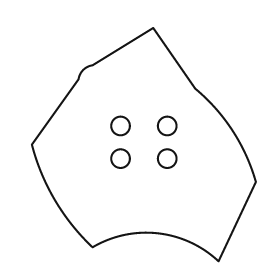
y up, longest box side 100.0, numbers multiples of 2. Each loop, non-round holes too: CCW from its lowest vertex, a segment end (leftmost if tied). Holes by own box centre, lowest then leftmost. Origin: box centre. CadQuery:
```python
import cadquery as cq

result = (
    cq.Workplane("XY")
    .moveTo(32.0, -50.0)
    .lineTo(48.0, -16.0)
    .threePointArc((38.0, 6.0), (22.0, 24.0))
    .lineTo(4.0, 50.0)
    .lineTo(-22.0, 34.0)
    .threePointArc((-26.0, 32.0), (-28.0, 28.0))
    .lineTo(-48.0, 0.0)
    .threePointArc((-38.0, -24.0), (-22.0, -44.0))
    .threePointArc((6.0, -38.0), (32.0, -50.0))
    .close()
    .moveTo(-10.0, -6.0)
    .circle(4.0)
    .moveTo(10.0, -6.0)
    .circle(4.0)
    .moveTo(-10.0, 8.0)
    .circle(4.0)
    .moveTo(10.0, 8.0)
    .circle(4.0)
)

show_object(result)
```